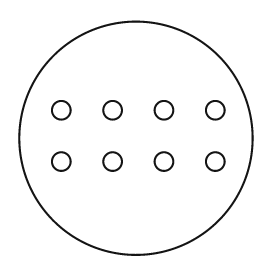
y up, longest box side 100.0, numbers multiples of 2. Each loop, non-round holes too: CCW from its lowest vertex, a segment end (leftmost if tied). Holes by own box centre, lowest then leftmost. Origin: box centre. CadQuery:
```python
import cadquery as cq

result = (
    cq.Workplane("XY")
    .moveTo(0.0, 0.0)
    .circle(50.0)
    .moveTo(-32.0, -10.0)
    .circle(4.0)
    .moveTo(-10.0, -10.0)
    .circle(4.0)
    .moveTo(12.0, -10.0)
    .circle(4.0)
    .moveTo(34.0, -10.0)
    .circle(4.0)
    .moveTo(-32.0, 12.0)
    .circle(4.0)
    .moveTo(-10.0, 12.0)
    .circle(4.0)
    .moveTo(12.0, 12.0)
    .circle(4.0)
    .moveTo(34.0, 12.0)
    .circle(4.0)
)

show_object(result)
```